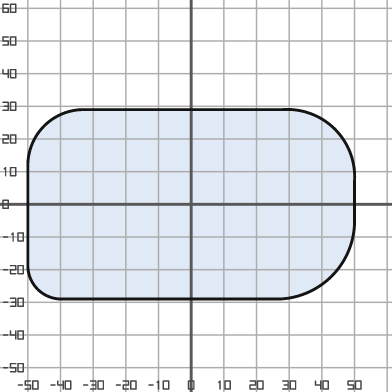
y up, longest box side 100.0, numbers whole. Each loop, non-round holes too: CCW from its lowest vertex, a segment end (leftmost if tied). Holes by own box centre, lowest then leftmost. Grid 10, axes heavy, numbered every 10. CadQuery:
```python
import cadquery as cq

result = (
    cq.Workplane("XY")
    .moveTo(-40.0, -29.0)
    .lineTo(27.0, -29.0)
    .threePointArc((43.0, -22.0), (50.0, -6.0))
    .lineTo(50.0, 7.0)
    .threePointArc((44.0, 23.0), (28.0, 29.0))
    .lineTo(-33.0, 29.0)
    .threePointArc((-45.0, 24.0), (-50.0, 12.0))
    .lineTo(-50.0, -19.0)
    .threePointArc((-47.0, -26.0), (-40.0, -29.0))
    .close()
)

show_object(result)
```